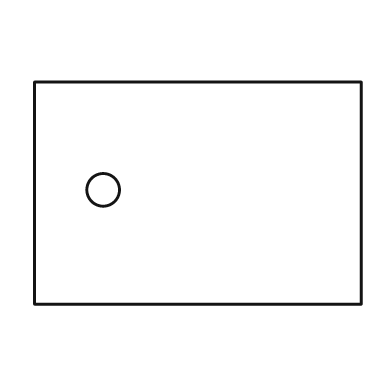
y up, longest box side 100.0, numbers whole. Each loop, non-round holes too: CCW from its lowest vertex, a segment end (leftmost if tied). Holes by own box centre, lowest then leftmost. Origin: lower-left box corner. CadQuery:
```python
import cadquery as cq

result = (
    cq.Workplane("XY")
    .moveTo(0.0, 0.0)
    .lineTo(100.0, 0.0)
    .lineTo(100.0, 68.0)
    .lineTo(0.0, 68.0)
    .close()
    .moveTo(21.0, 35.0)
    .circle(5.0)
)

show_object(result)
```